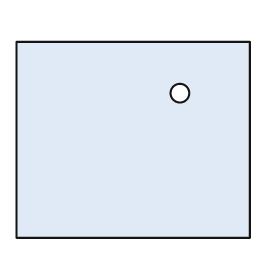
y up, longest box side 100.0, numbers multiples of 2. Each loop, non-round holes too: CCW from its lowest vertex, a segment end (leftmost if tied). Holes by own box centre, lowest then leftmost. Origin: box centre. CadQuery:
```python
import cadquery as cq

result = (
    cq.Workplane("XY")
    .moveTo(-50.0, -42.0)
    .lineTo(50.0, -42.0)
    .lineTo(50.0, 42.0)
    .lineTo(-50.0, 42.0)
    .close()
    .moveTo(20.0, 20.0)
    .circle(4.0)
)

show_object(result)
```